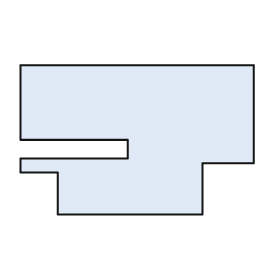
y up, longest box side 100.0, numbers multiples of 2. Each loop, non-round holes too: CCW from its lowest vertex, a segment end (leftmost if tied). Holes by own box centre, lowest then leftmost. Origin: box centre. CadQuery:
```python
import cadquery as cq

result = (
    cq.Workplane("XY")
    .moveTo(-34.0, -32.0)
    .lineTo(28.0, -32.0)
    .lineTo(28.0, -10.0)
    .lineTo(50.0, -10.0)
    .lineTo(50.0, 32.0)
    .lineTo(-50.0, 32.0)
    .lineTo(-50.0, 0.0)
    .lineTo(-4.0, 0.0)
    .lineTo(-4.0, -8.0)
    .lineTo(-50.0, -8.0)
    .lineTo(-50.0, -14.0)
    .lineTo(-34.0, -14.0)
    .close()
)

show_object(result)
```